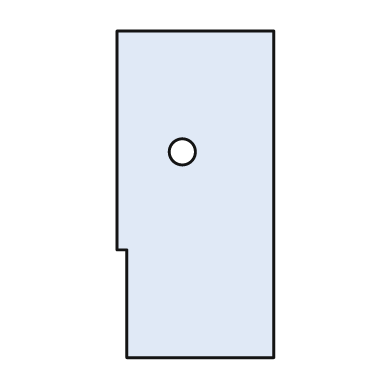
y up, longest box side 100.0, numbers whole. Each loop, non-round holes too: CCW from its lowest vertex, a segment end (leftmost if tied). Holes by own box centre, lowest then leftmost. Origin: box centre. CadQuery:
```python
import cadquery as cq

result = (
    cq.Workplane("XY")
    .moveTo(-21.0, -50.0)
    .lineTo(24.0, -50.0)
    .lineTo(24.0, 50.0)
    .lineTo(-24.0, 50.0)
    .lineTo(-24.0, -17.0)
    .lineTo(-21.0, -17.0)
    .close()
    .moveTo(-4.0, 13.0)
    .circle(4.0)
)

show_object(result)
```